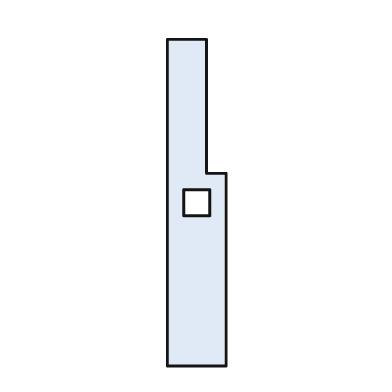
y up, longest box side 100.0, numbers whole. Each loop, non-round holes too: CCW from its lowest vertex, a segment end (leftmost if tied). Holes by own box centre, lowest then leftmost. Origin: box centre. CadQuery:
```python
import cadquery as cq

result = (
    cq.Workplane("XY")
    .moveTo(-9.0, -50.0)
    .lineTo(9.0, -50.0)
    .lineTo(9.0, 9.0)
    .lineTo(3.0, 9.0)
    .lineTo(3.0, 50.0)
    .lineTo(-9.0, 50.0)
    .close()
    .moveTo(-4.0, -4.0)
    .lineTo(4.0, -4.0)
    .lineTo(4.0, 4.0)
    .lineTo(-4.0, 4.0)
    .close()
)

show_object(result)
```